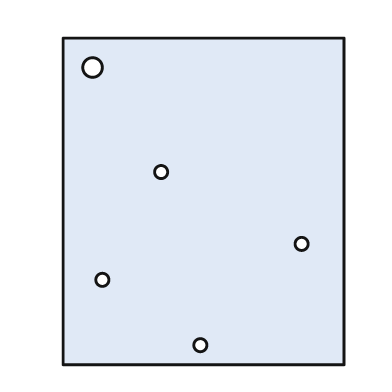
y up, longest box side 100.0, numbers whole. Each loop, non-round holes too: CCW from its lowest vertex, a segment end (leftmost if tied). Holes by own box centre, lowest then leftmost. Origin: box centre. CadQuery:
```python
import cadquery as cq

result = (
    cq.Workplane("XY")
    .moveTo(-43.0, -50.0)
    .lineTo(43.0, -50.0)
    .lineTo(43.0, 50.0)
    .lineTo(-43.0, 50.0)
    .close()
    .moveTo(-1.0, -44.0)
    .circle(2.0)
    .moveTo(-31.0, -24.0)
    .circle(2.0)
    .moveTo(30.0, -13.0)
    .circle(2.0)
    .moveTo(-13.0, 9.0)
    .circle(2.0)
    .moveTo(-34.0, 41.0)
    .circle(3.0)
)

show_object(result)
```